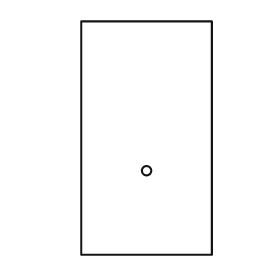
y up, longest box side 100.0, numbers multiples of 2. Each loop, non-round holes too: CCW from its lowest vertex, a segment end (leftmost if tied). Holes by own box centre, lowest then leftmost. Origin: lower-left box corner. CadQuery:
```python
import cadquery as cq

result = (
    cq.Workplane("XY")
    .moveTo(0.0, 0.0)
    .lineTo(56.0, 0.0)
    .lineTo(56.0, 100.0)
    .lineTo(0.0, 100.0)
    .close()
    .moveTo(28.0, 36.0)
    .circle(2.0)
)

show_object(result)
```